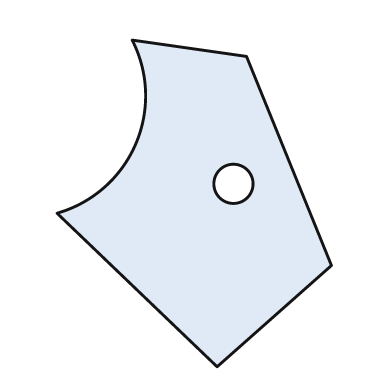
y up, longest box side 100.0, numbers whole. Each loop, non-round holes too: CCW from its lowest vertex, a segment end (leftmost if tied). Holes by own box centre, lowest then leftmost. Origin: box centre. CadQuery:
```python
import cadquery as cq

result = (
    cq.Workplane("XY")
    .moveTo(7.0, -50.0)
    .lineTo(42.0, -19.0)
    .lineTo(16.0, 45.0)
    .lineTo(-19.0, 50.0)
    .threePointArc((-18.0, 18.0), (-42.0, -3.0))
    .close()
    .moveTo(12.0, 6.0)
    .circle(6.0)
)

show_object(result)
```